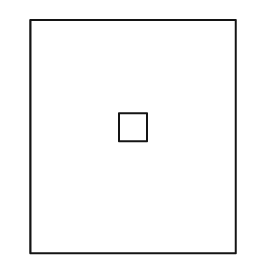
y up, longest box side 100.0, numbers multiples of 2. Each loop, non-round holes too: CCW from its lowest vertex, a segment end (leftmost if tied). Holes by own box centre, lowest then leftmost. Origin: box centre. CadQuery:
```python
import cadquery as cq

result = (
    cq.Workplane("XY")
    .moveTo(-44.0, -50.0)
    .lineTo(44.0, -50.0)
    .lineTo(44.0, 50.0)
    .lineTo(-44.0, 50.0)
    .close()
    .moveTo(-6.0, -2.0)
    .lineTo(6.0, -2.0)
    .lineTo(6.0, 10.0)
    .lineTo(-6.0, 10.0)
    .close()
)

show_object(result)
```